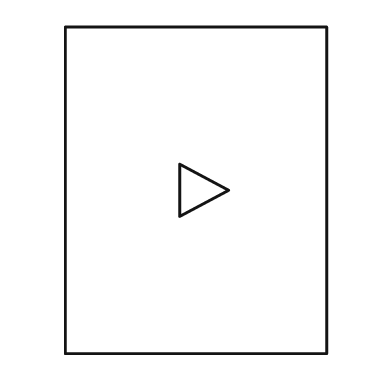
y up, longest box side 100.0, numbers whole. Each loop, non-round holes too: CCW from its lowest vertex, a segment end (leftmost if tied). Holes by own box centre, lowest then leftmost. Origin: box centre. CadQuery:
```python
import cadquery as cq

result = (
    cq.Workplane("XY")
    .moveTo(-40.0, -50.0)
    .lineTo(40.0, -50.0)
    .lineTo(40.0, 50.0)
    .lineTo(-40.0, 50.0)
    .close()
    .moveTo(-5.0, -8.0)
    .lineTo(10.0, 0.0)
    .lineTo(-5.0, 8.0)
    .close()
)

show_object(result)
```